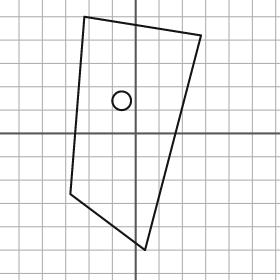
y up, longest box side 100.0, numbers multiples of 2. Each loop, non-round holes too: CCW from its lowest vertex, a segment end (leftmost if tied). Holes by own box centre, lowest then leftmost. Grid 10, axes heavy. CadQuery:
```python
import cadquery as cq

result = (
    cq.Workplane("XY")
    .moveTo(4.0, -50.0)
    .lineTo(28.0, 42.0)
    .lineTo(-22.0, 50.0)
    .lineTo(-28.0, -26.0)
    .close()
    .moveTo(-6.0, 14.0)
    .circle(4.0)
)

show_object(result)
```